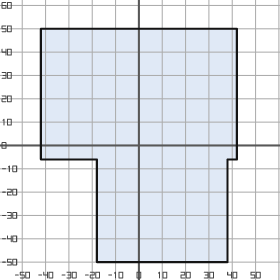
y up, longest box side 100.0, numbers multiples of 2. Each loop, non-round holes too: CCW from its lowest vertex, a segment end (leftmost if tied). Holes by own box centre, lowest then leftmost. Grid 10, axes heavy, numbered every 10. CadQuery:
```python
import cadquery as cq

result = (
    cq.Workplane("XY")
    .moveTo(-18.0, -50.0)
    .lineTo(38.0, -50.0)
    .lineTo(38.0, -6.0)
    .lineTo(42.0, -6.0)
    .lineTo(42.0, 50.0)
    .lineTo(-42.0, 50.0)
    .lineTo(-42.0, -6.0)
    .lineTo(-18.0, -6.0)
    .close()
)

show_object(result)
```